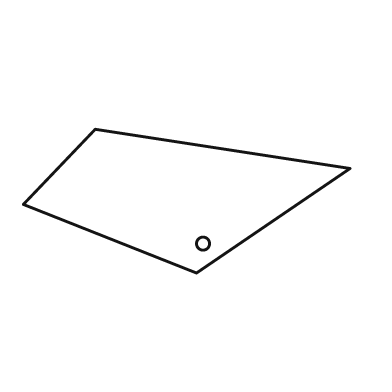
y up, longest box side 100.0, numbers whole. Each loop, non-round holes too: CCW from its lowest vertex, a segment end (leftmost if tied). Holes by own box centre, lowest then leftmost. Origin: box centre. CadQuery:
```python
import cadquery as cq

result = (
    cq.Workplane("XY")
    .moveTo(3.0, -22.0)
    .lineTo(50.0, 10.0)
    .lineTo(-28.0, 22.0)
    .lineTo(-50.0, -1.0)
    .close()
    .moveTo(5.0, -13.0)
    .circle(2.0)
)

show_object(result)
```